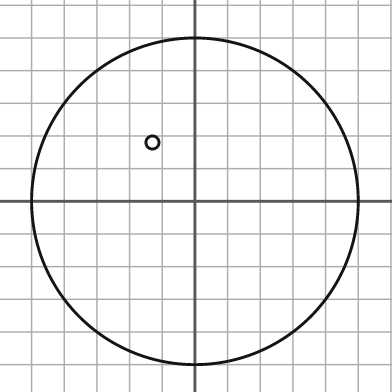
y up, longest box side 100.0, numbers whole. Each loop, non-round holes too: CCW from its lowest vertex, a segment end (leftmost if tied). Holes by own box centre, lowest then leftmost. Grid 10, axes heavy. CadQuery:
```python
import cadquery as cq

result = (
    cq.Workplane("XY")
    .moveTo(0.0, 0.0)
    .circle(50.0)
    .moveTo(-13.0, 18.0)
    .circle(2.0)
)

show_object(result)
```